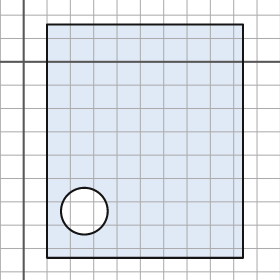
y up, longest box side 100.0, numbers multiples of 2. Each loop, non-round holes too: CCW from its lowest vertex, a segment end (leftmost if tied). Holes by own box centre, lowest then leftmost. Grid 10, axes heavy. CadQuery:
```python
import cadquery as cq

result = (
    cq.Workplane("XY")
    .moveTo(10.0, -84.0)
    .lineTo(94.0, -84.0)
    .lineTo(94.0, 16.0)
    .lineTo(10.0, 16.0)
    .close()
    .moveTo(26.0, -64.0)
    .circle(10.0)
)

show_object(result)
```